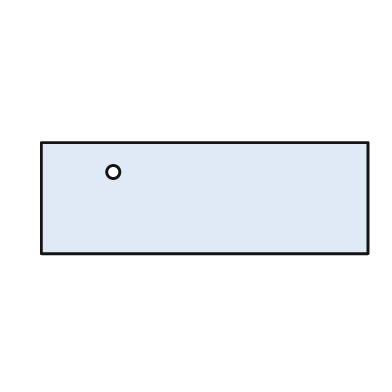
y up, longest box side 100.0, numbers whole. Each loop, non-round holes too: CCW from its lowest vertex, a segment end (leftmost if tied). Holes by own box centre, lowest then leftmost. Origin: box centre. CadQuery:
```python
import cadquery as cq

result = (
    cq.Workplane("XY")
    .moveTo(-50.0, -17.0)
    .lineTo(50.0, -17.0)
    .lineTo(50.0, 17.0)
    .lineTo(-50.0, 17.0)
    .close()
    .moveTo(-28.0, 8.0)
    .circle(2.0)
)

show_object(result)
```